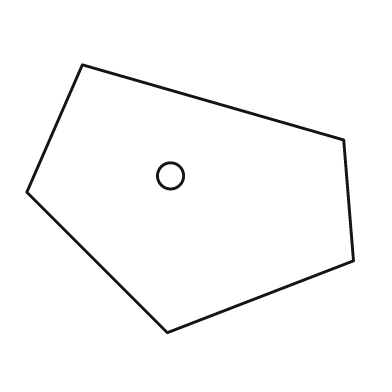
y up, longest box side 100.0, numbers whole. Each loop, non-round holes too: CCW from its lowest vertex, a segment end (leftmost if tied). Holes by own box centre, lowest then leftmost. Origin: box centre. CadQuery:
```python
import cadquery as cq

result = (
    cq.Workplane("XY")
    .moveTo(-7.0, -41.0)
    .lineTo(50.0, -19.0)
    .lineTo(47.0, 18.0)
    .lineTo(-33.0, 41.0)
    .lineTo(-50.0, 2.0)
    .close()
    .moveTo(-6.0, 7.0)
    .circle(4.0)
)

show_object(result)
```